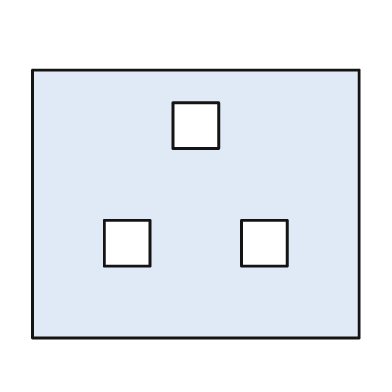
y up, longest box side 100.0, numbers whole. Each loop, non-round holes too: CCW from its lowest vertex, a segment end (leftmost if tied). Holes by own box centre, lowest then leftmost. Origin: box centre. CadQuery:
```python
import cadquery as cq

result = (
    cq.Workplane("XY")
    .moveTo(-50.0, -41.0)
    .lineTo(50.0, -41.0)
    .lineTo(50.0, 41.0)
    .lineTo(-50.0, 41.0)
    .close()
    .moveTo(-28.0, -19.0)
    .lineTo(-14.0, -19.0)
    .lineTo(-14.0, -5.0)
    .lineTo(-28.0, -5.0)
    .close()
    .moveTo(14.0, -19.0)
    .lineTo(28.0, -19.0)
    .lineTo(28.0, -5.0)
    .lineTo(14.0, -5.0)
    .close()
    .moveTo(-7.0, 17.0)
    .lineTo(7.0, 17.0)
    .lineTo(7.0, 31.0)
    .lineTo(-7.0, 31.0)
    .close()
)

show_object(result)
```